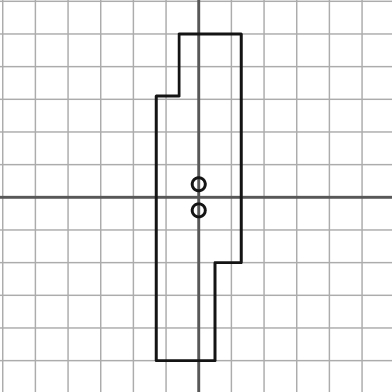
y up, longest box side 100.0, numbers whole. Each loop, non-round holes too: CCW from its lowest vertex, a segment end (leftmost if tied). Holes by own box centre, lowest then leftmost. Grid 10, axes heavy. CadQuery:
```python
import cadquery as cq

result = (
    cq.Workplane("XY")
    .moveTo(-13.0, -50.0)
    .lineTo(5.0, -50.0)
    .lineTo(5.0, -20.0)
    .lineTo(13.0, -20.0)
    .lineTo(13.0, 50.0)
    .lineTo(-6.0, 50.0)
    .lineTo(-6.0, 31.0)
    .lineTo(-13.0, 31.0)
    .close()
    .moveTo(0.0, -4.0)
    .circle(2.0)
    .moveTo(0.0, 4.0)
    .circle(2.0)
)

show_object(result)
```